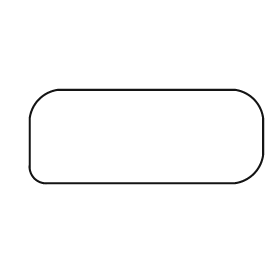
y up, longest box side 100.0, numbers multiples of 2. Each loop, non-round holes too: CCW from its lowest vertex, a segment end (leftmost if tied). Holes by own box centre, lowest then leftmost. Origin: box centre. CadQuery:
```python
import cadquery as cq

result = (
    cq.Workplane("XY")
    .moveTo(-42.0, -20.0)
    .lineTo(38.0, -20.0)
    .threePointArc((46.0, -16.0), (50.0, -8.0))
    .lineTo(50.0, 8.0)
    .threePointArc((46.0, 16.0), (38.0, 20.0))
    .lineTo(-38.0, 20.0)
    .threePointArc((-46.0, 16.0), (-50.0, 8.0))
    .lineTo(-50.0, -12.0)
    .threePointArc((-48.0, -18.0), (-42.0, -20.0))
    .close()
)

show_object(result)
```